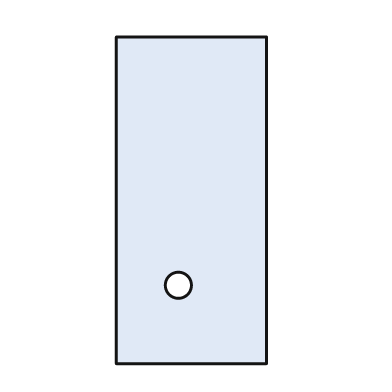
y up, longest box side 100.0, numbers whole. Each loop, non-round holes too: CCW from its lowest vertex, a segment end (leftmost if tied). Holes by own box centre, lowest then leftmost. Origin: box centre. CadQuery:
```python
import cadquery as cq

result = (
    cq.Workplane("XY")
    .moveTo(-23.0, -50.0)
    .lineTo(23.0, -50.0)
    .lineTo(23.0, 50.0)
    .lineTo(-23.0, 50.0)
    .close()
    .moveTo(-4.0, -26.0)
    .circle(4.0)
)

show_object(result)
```